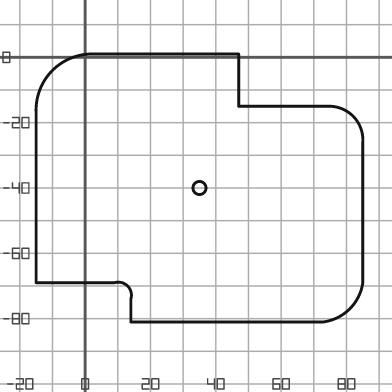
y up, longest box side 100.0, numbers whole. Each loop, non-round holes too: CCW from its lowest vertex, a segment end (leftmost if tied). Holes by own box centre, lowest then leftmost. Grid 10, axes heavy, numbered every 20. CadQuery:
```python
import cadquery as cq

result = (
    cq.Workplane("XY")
    .moveTo(14.0, -81.0)
    .lineTo(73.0, -81.0)
    .threePointArc((81.0, -77.0), (85.0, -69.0))
    .lineTo(85.0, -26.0)
    .threePointArc((82.0, -18.0), (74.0, -15.0))
    .lineTo(47.0, -15.0)
    .lineTo(47.0, 1.0)
    .lineTo(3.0, 1.0)
    .threePointArc((-10.0, -4.0), (-15.0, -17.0))
    .lineTo(-15.0, -69.0)
    .lineTo(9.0, -69.0)
    .threePointArc((13.0, -70.0), (14.0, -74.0))
    .close()
    .moveTo(35.0, -40.0)
    .circle(2.0)
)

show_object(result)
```